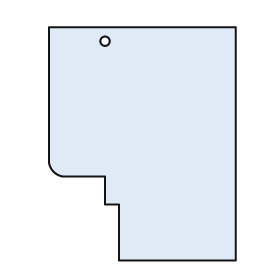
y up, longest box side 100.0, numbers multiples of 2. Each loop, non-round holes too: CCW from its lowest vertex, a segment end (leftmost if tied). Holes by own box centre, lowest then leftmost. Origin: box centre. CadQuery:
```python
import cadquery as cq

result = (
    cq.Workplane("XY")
    .moveTo(-10.0, -50.0)
    .lineTo(40.0, -50.0)
    .lineTo(40.0, 50.0)
    .lineTo(-40.0, 50.0)
    .lineTo(-40.0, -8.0)
    .threePointArc((-38.0, -12.0), (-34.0, -14.0))
    .lineTo(-16.0, -14.0)
    .lineTo(-16.0, -26.0)
    .lineTo(-10.0, -26.0)
    .close()
    .moveTo(-16.0, 44.0)
    .circle(2.0)
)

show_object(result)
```